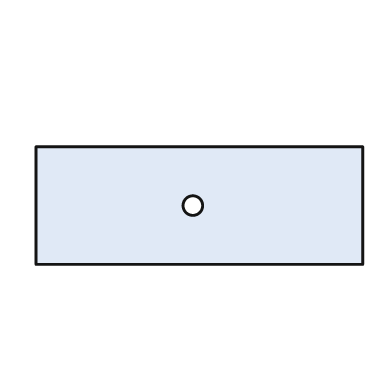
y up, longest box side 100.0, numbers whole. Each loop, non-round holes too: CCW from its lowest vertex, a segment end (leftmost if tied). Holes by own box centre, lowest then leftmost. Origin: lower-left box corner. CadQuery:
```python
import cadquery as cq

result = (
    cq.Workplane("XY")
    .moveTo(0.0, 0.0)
    .lineTo(100.0, 0.0)
    .lineTo(100.0, 36.0)
    .lineTo(0.0, 36.0)
    .close()
    .moveTo(48.0, 18.0)
    .circle(3.0)
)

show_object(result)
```